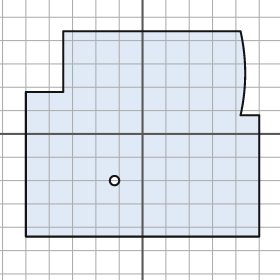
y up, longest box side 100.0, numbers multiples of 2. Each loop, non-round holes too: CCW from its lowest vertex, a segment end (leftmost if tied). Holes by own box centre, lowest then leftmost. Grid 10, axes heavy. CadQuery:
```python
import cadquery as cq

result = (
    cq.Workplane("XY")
    .moveTo(-50.0, -44.0)
    .lineTo(50.0, -44.0)
    .lineTo(50.0, 8.0)
    .lineTo(42.0, 8.0)
    .threePointArc((44.0, 26.0), (42.0, 44.0))
    .lineTo(-34.0, 44.0)
    .lineTo(-34.0, 18.0)
    .lineTo(-50.0, 18.0)
    .close()
    .moveTo(-12.0, -20.0)
    .circle(2.0)
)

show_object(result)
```